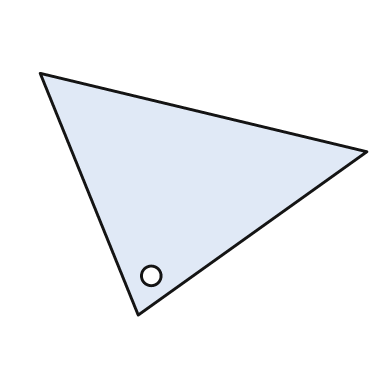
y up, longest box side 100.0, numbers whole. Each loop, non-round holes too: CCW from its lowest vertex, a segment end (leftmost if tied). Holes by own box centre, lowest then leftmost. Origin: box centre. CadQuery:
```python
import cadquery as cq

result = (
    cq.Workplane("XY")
    .moveTo(-20.0, -37.0)
    .lineTo(50.0, 13.0)
    .lineTo(-50.0, 37.0)
    .close()
    .moveTo(-16.0, -25.0)
    .circle(3.0)
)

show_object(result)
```